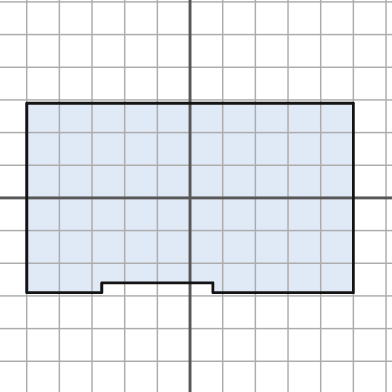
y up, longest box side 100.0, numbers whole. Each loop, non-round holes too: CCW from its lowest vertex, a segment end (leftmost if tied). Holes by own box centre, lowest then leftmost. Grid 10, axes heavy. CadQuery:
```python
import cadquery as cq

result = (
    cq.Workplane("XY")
    .moveTo(-50.0, -29.0)
    .lineTo(-27.0, -29.0)
    .lineTo(-27.0, -26.0)
    .lineTo(7.0, -26.0)
    .lineTo(7.0, -29.0)
    .lineTo(50.0, -29.0)
    .lineTo(50.0, 29.0)
    .lineTo(-50.0, 29.0)
    .close()
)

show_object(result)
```